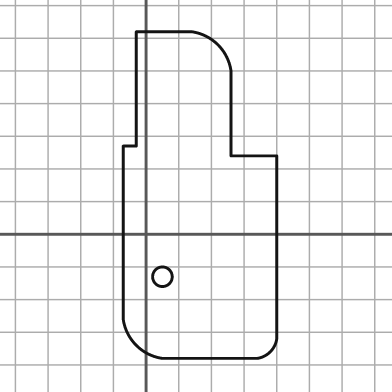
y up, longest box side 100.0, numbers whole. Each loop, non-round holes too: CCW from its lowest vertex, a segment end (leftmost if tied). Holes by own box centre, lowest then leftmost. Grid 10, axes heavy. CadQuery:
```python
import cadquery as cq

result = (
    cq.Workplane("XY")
    .moveTo(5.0, -38.0)
    .lineTo(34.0, -38.0)
    .threePointArc((38.0, -36.0), (40.0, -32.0))
    .lineTo(40.0, 24.0)
    .lineTo(26.0, 24.0)
    .lineTo(26.0, 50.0)
    .threePointArc((22.0, 58.0), (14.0, 62.0))
    .lineTo(-3.0, 62.0)
    .lineTo(-3.0, 27.0)
    .lineTo(-7.0, 27.0)
    .lineTo(-7.0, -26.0)
    .threePointArc((-3.0, -34.0), (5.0, -38.0))
    .close()
    .moveTo(5.0, -13.0)
    .circle(3.0)
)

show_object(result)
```